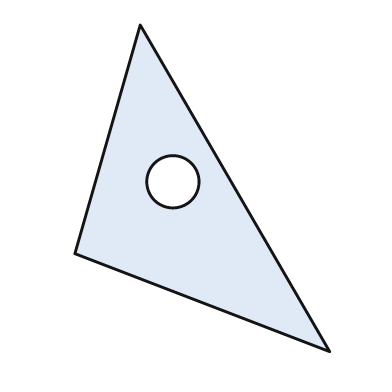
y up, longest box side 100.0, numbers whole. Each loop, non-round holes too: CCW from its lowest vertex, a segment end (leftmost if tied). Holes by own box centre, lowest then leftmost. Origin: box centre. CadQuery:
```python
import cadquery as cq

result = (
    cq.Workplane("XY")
    .moveTo(39.0, -50.0)
    .lineTo(-19.0, 50.0)
    .lineTo(-39.0, -20.0)
    .close()
    .moveTo(-9.0, 2.0)
    .circle(8.0)
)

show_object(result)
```